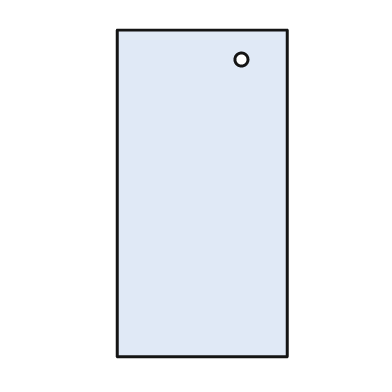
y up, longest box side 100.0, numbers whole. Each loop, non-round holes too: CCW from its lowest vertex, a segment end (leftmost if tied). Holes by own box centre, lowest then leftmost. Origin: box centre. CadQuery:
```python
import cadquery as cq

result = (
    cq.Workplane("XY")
    .moveTo(-26.0, -50.0)
    .lineTo(26.0, -50.0)
    .lineTo(26.0, 50.0)
    .lineTo(-26.0, 50.0)
    .close()
    .moveTo(12.0, 41.0)
    .circle(2.0)
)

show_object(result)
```